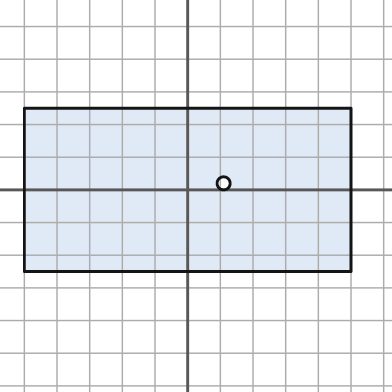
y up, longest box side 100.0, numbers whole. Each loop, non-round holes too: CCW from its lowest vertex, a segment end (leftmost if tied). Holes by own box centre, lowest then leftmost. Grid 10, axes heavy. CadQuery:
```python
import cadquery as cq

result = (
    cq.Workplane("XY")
    .moveTo(-50.0, -25.0)
    .lineTo(50.0, -25.0)
    .lineTo(50.0, 25.0)
    .lineTo(-50.0, 25.0)
    .close()
    .moveTo(11.0, 2.0)
    .circle(2.0)
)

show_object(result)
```